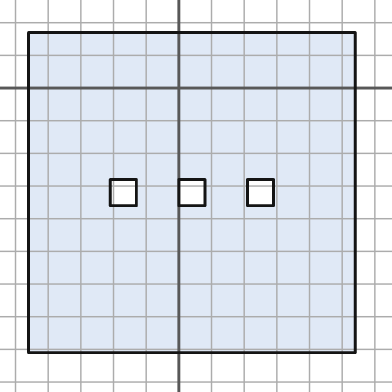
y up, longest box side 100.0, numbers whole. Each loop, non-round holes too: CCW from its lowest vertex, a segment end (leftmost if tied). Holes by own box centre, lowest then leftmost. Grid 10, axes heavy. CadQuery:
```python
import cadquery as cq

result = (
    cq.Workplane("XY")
    .moveTo(-46.0, -81.0)
    .lineTo(54.0, -81.0)
    .lineTo(54.0, 17.0)
    .lineTo(-46.0, 17.0)
    .close()
    .moveTo(-21.0, -36.0)
    .lineTo(-13.0, -36.0)
    .lineTo(-13.0, -28.0)
    .lineTo(-21.0, -28.0)
    .close()
    .moveTo(0.0, -36.0)
    .lineTo(8.0, -36.0)
    .lineTo(8.0, -28.0)
    .lineTo(0.0, -28.0)
    .close()
    .moveTo(21.0, -36.0)
    .lineTo(29.0, -36.0)
    .lineTo(29.0, -28.0)
    .lineTo(21.0, -28.0)
    .close()
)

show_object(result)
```